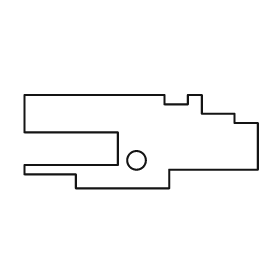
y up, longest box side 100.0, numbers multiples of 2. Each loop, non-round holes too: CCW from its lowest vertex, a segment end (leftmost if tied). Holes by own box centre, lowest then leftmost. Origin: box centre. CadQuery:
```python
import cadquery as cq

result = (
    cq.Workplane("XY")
    .moveTo(-28.0, -20.0)
    .lineTo(12.0, -20.0)
    .lineTo(12.0, -12.0)
    .lineTo(50.0, -12.0)
    .lineTo(50.0, 8.0)
    .lineTo(40.0, 8.0)
    .lineTo(40.0, 12.0)
    .lineTo(26.0, 12.0)
    .lineTo(26.0, 20.0)
    .lineTo(20.0, 20.0)
    .lineTo(20.0, 16.0)
    .lineTo(10.0, 16.0)
    .lineTo(10.0, 20.0)
    .lineTo(-50.0, 20.0)
    .lineTo(-50.0, 4.0)
    .lineTo(-10.0, 4.0)
    .lineTo(-10.0, -10.0)
    .lineTo(-50.0, -10.0)
    .lineTo(-50.0, -14.0)
    .lineTo(-28.0, -14.0)
    .close()
    .moveTo(-2.0, -8.0)
    .circle(4.0)
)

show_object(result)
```